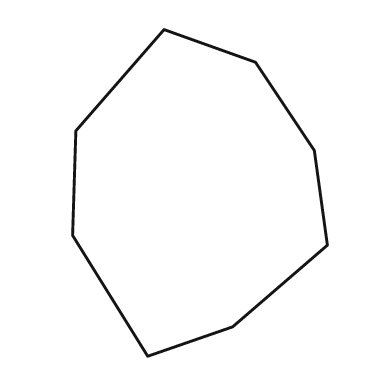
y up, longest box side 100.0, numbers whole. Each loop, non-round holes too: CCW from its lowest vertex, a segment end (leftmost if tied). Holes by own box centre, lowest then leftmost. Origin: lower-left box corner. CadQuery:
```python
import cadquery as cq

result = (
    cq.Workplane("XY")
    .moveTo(23.0, 0.0)
    .lineTo(49.0, 9.0)
    .lineTo(78.0, 34.0)
    .lineTo(74.0, 63.0)
    .lineTo(56.0, 90.0)
    .lineTo(28.0, 100.0)
    .lineTo(1.0, 69.0)
    .lineTo(0.0, 37.0)
    .close()
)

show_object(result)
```